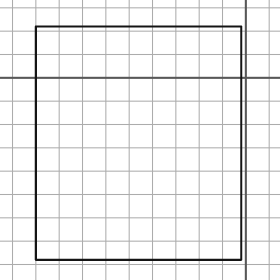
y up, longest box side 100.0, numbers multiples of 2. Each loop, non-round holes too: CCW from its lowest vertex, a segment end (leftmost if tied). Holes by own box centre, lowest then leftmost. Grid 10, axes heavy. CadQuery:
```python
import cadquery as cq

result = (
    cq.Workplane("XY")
    .moveTo(-90.0, -78.0)
    .lineTo(-2.0, -78.0)
    .lineTo(-2.0, 22.0)
    .lineTo(-90.0, 22.0)
    .close()
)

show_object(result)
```